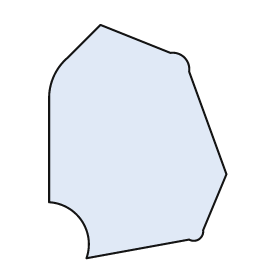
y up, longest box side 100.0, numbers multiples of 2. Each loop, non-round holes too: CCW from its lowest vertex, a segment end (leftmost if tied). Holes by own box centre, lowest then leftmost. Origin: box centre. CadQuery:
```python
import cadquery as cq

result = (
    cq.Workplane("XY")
    .moveTo(-22.0, -50.0)
    .lineTo(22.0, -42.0)
    .threePointArc((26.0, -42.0), (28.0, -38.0))
    .lineTo(38.0, -14.0)
    .lineTo(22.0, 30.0)
    .threePointArc((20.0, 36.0), (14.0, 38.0))
    .lineTo(-16.0, 50.0)
    .lineTo(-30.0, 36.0)
    .threePointArc((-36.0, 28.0), (-38.0, 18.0))
    .lineTo(-38.0, -26.0)
    .threePointArc((-24.0, -34.0), (-22.0, -50.0))
    .close()
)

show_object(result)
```